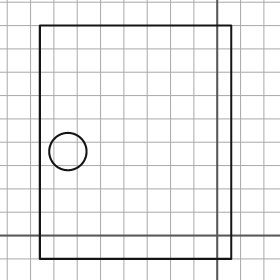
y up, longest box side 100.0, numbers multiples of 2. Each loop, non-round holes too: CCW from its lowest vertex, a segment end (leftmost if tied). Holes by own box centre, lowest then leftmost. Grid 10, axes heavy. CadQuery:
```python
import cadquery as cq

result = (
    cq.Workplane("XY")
    .moveTo(-76.0, -10.0)
    .lineTo(6.0, -10.0)
    .lineTo(6.0, 90.0)
    .lineTo(-76.0, 90.0)
    .close()
    .moveTo(-64.0, 36.0)
    .circle(8.0)
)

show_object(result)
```